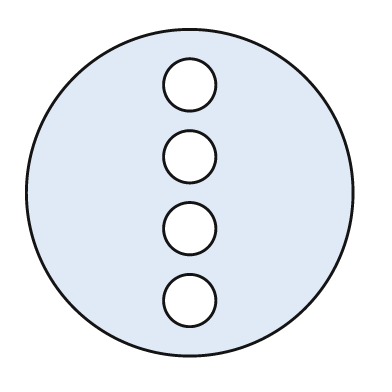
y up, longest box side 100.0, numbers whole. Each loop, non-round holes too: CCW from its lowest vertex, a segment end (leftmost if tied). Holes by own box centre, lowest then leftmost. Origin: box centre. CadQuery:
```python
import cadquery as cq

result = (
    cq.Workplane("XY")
    .moveTo(0.0, 0.0)
    .circle(50.0)
    .moveTo(0.0, -33.0)
    .circle(8.0)
    .moveTo(0.0, -11.0)
    .circle(8.0)
    .moveTo(0.0, 11.0)
    .circle(8.0)
    .moveTo(0.0, 33.0)
    .circle(8.0)
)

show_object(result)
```